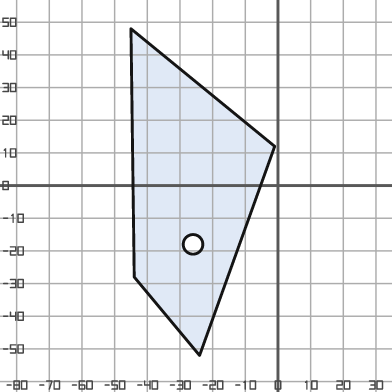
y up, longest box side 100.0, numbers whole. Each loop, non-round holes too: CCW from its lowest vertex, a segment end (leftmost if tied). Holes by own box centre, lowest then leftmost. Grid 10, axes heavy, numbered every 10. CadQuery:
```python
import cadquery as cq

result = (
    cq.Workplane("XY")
    .moveTo(-24.0, -52.0)
    .lineTo(-1.0, 12.0)
    .lineTo(-45.0, 48.0)
    .lineTo(-44.0, -28.0)
    .close()
    .moveTo(-26.0, -18.0)
    .circle(3.0)
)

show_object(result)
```